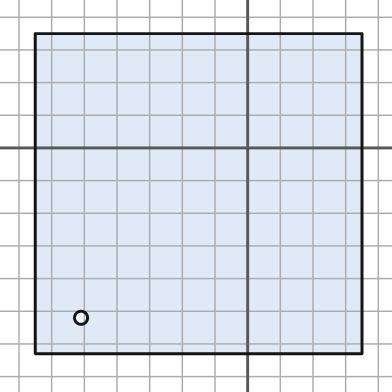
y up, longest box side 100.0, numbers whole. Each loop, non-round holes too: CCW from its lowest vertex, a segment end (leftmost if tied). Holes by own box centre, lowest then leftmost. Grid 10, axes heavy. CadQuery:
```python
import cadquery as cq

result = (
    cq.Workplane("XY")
    .moveTo(-65.0, -63.0)
    .lineTo(35.0, -63.0)
    .lineTo(35.0, 35.0)
    .lineTo(-65.0, 35.0)
    .close()
    .moveTo(-51.0, -52.0)
    .circle(2.0)
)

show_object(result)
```